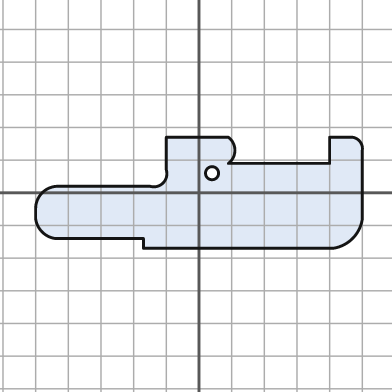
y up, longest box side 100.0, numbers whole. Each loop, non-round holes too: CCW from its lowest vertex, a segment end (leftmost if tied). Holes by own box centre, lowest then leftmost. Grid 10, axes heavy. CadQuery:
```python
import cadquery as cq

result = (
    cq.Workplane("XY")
    .moveTo(-17.0, -17.0)
    .lineTo(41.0, -17.0)
    .threePointArc((47.0, -14.0), (50.0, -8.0))
    .lineTo(50.0, 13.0)
    .threePointArc((49.0, 16.0), (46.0, 17.0))
    .lineTo(40.0, 17.0)
    .lineTo(40.0, 9.0)
    .lineTo(9.0, 9.0)
    .threePointArc((11.0, 13.0), (9.0, 17.0))
    .lineTo(-10.0, 17.0)
    .lineTo(-10.0, 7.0)
    .threePointArc((-11.0, 3.0), (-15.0, 2.0))
    .lineTo(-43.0, 2.0)
    .threePointArc((-48.0, 0.0), (-50.0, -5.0))
    .lineTo(-50.0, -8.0)
    .threePointArc((-48.0, -12.0), (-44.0, -14.0))
    .lineTo(-17.0, -14.0)
    .close()
    .moveTo(4.0, 6.0)
    .circle(2.0)
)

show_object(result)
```